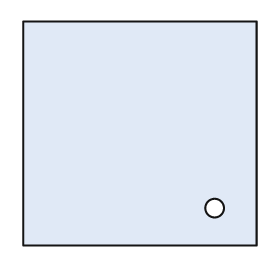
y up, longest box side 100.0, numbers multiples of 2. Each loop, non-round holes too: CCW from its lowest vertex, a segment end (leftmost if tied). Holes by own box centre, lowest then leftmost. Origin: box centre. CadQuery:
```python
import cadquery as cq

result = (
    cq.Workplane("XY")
    .moveTo(-50.0, -48.0)
    .lineTo(50.0, -48.0)
    .lineTo(50.0, 48.0)
    .lineTo(-50.0, 48.0)
    .close()
    .moveTo(32.0, -32.0)
    .circle(4.0)
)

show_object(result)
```